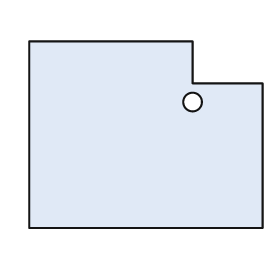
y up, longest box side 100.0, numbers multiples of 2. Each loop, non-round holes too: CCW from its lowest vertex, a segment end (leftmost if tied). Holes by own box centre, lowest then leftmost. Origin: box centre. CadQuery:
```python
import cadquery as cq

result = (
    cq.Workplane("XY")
    .moveTo(-50.0, -40.0)
    .lineTo(50.0, -40.0)
    .lineTo(50.0, 22.0)
    .lineTo(20.0, 22.0)
    .lineTo(20.0, 40.0)
    .lineTo(-50.0, 40.0)
    .close()
    .moveTo(20.0, 14.0)
    .circle(4.0)
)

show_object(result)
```